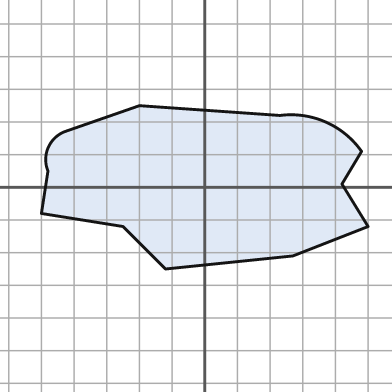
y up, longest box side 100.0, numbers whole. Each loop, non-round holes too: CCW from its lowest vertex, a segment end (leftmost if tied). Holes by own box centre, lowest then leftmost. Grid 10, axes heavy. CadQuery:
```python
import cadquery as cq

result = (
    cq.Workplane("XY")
    .moveTo(-12.0, -25.0)
    .lineTo(27.0, -21.0)
    .lineTo(50.0, -12.0)
    .lineTo(42.0, 1.0)
    .lineTo(48.0, 11.0)
    .threePointArc((37.0, 20.0), (23.0, 22.0))
    .lineTo(-20.0, 25.0)
    .lineTo(-43.0, 17.0)
    .threePointArc((-48.0, 12.0), (-48.0, 5.0))
    .lineTo(-50.0, -8.0)
    .lineTo(-25.0, -12.0)
    .close()
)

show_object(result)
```